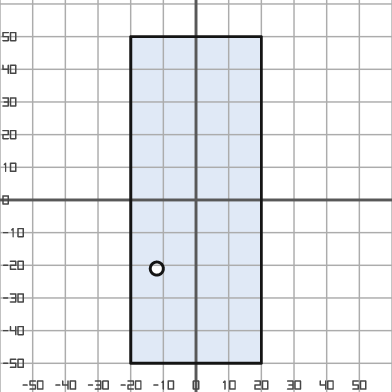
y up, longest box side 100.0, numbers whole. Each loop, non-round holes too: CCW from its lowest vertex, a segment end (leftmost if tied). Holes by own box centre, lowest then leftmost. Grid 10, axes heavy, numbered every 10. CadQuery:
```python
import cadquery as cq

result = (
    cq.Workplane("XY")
    .moveTo(-20.0, -50.0)
    .lineTo(20.0, -50.0)
    .lineTo(20.0, 50.0)
    .lineTo(-20.0, 50.0)
    .close()
    .moveTo(-12.0, -21.0)
    .circle(2.0)
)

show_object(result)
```